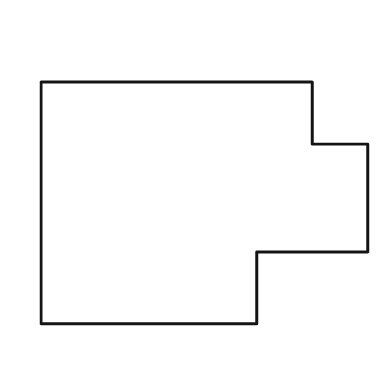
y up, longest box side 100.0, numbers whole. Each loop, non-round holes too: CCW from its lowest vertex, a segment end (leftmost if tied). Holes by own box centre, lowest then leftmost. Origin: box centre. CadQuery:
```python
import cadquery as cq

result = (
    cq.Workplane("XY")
    .moveTo(-50.0, -37.0)
    .lineTo(16.0, -37.0)
    .lineTo(16.0, -15.0)
    .lineTo(50.0, -15.0)
    .lineTo(50.0, 18.0)
    .lineTo(33.0, 18.0)
    .lineTo(33.0, 37.0)
    .lineTo(-50.0, 37.0)
    .close()
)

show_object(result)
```